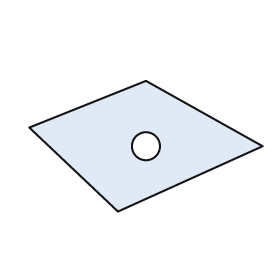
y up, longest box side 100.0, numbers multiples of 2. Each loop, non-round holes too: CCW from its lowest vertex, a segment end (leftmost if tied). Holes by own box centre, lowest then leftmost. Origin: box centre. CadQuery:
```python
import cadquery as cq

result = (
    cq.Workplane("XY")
    .moveTo(-12.0, -28.0)
    .lineTo(50.0, 0.0)
    .lineTo(0.0, 28.0)
    .lineTo(-50.0, 8.0)
    .close()
    .moveTo(0.0, 0.0)
    .circle(6.0)
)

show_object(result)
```